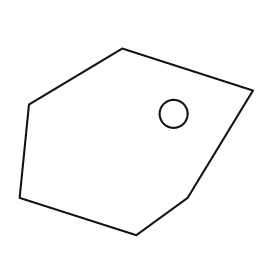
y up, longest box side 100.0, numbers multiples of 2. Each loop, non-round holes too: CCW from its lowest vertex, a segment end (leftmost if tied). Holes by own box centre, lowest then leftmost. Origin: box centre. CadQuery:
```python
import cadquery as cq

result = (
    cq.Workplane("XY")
    .moveTo(0.0, -40.0)
    .lineTo(22.0, -24.0)
    .lineTo(50.0, 22.0)
    .lineTo(-6.0, 40.0)
    .lineTo(-46.0, 16.0)
    .lineTo(-50.0, -24.0)
    .close()
    .moveTo(16.0, 12.0)
    .circle(6.0)
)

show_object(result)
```